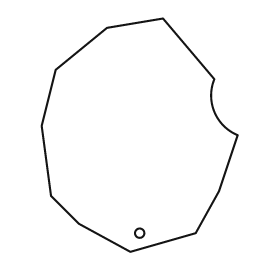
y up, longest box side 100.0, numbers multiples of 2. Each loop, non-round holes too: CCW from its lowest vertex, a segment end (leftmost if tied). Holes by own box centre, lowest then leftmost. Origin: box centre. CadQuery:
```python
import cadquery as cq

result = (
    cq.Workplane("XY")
    .moveTo(-4.0, -50.0)
    .lineTo(24.0, -42.0)
    .lineTo(34.0, -24.0)
    .lineTo(42.0, 0.0)
    .threePointArc((32.0, 10.0), (32.0, 24.0))
    .lineTo(10.0, 50.0)
    .lineTo(-14.0, 46.0)
    .lineTo(-36.0, 28.0)
    .lineTo(-42.0, 4.0)
    .lineTo(-38.0, -26.0)
    .lineTo(-26.0, -38.0)
    .close()
    .moveTo(0.0, -42.0)
    .circle(2.0)
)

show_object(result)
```